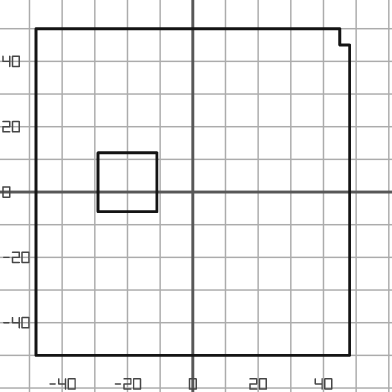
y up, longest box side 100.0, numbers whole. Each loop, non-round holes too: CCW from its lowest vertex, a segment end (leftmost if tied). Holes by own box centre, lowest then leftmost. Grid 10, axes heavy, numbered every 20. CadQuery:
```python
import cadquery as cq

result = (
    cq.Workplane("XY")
    .moveTo(-48.0, -50.0)
    .lineTo(48.0, -50.0)
    .lineTo(48.0, 45.0)
    .lineTo(45.0, 45.0)
    .lineTo(45.0, 50.0)
    .lineTo(-48.0, 50.0)
    .close()
    .moveTo(-29.0, -6.0)
    .lineTo(-11.0, -6.0)
    .lineTo(-11.0, 12.0)
    .lineTo(-29.0, 12.0)
    .close()
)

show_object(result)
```